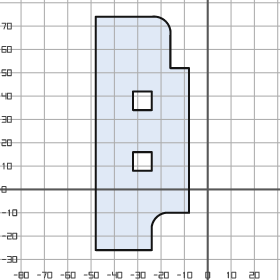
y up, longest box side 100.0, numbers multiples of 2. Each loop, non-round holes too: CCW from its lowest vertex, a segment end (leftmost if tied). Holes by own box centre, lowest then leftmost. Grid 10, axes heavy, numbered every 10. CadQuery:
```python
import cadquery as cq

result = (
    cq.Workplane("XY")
    .moveTo(-48.0, -26.0)
    .lineTo(-24.0, -26.0)
    .lineTo(-24.0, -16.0)
    .threePointArc((-22.0, -12.0), (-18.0, -10.0))
    .lineTo(-8.0, -10.0)
    .lineTo(-8.0, 52.0)
    .lineTo(-16.0, 52.0)
    .lineTo(-16.0, 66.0)
    .threePointArc((-18.0, 72.0), (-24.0, 74.0))
    .lineTo(-48.0, 74.0)
    .close()
    .moveTo(-32.0, 8.0)
    .lineTo(-24.0, 8.0)
    .lineTo(-24.0, 16.0)
    .lineTo(-32.0, 16.0)
    .close()
    .moveTo(-32.0, 34.0)
    .lineTo(-24.0, 34.0)
    .lineTo(-24.0, 42.0)
    .lineTo(-32.0, 42.0)
    .close()
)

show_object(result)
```